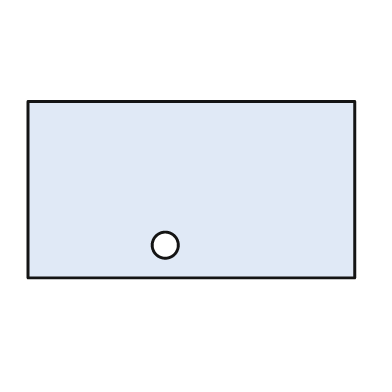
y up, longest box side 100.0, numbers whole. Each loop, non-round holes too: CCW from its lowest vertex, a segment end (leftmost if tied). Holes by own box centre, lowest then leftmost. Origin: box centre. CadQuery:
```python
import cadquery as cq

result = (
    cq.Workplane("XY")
    .moveTo(-50.0, -27.0)
    .lineTo(50.0, -27.0)
    .lineTo(50.0, 27.0)
    .lineTo(-50.0, 27.0)
    .close()
    .moveTo(-8.0, -17.0)
    .circle(4.0)
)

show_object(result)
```